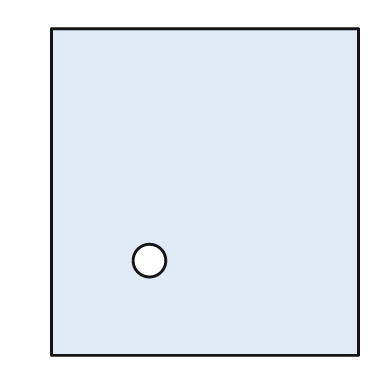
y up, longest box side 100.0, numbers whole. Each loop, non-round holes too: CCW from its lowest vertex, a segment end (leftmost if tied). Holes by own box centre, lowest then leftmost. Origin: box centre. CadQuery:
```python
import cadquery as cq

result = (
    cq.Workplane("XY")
    .moveTo(-47.0, -50.0)
    .lineTo(47.0, -50.0)
    .lineTo(47.0, 50.0)
    .lineTo(-47.0, 50.0)
    .close()
    .moveTo(-17.0, -21.0)
    .circle(5.0)
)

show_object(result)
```